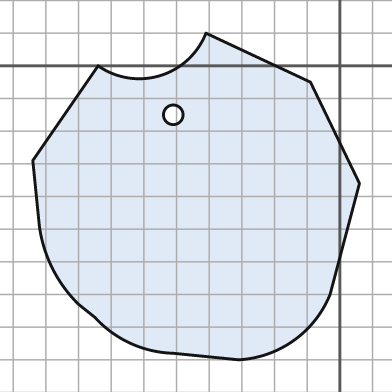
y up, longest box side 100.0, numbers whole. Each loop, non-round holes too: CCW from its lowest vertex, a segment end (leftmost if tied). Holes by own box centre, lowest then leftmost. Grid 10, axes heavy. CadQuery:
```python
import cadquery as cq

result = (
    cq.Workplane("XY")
    .moveTo(-31.0, -90.0)
    .threePointArc((-14.0, -84.0), (-3.0, -70.0))
    .lineTo(6.0, -36.0)
    .lineTo(-9.0, -5.0)
    .lineTo(-41.0, 10.0)
    .threePointArc((-55.0, -3.0), (-74.0, 0.0))
    .lineTo(-94.0, -29.0)
    .lineTo(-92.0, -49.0)
    .threePointArc((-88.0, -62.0), (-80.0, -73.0))
    .lineTo(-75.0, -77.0)
    .threePointArc((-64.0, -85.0), (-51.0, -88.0))
    .close()
    .moveTo(-51.0, -15.0)
    .circle(3.0)
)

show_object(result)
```